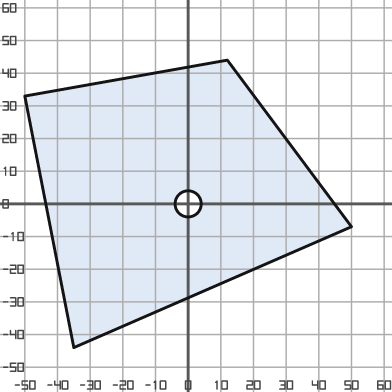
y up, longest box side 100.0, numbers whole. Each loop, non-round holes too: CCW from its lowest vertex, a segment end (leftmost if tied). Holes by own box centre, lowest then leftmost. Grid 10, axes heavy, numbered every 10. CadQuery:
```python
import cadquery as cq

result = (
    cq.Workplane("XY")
    .moveTo(-35.0, -44.0)
    .lineTo(50.0, -7.0)
    .lineTo(12.0, 44.0)
    .lineTo(-50.0, 33.0)
    .close()
    .moveTo(0.0, 0.0)
    .circle(4.0)
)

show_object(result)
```